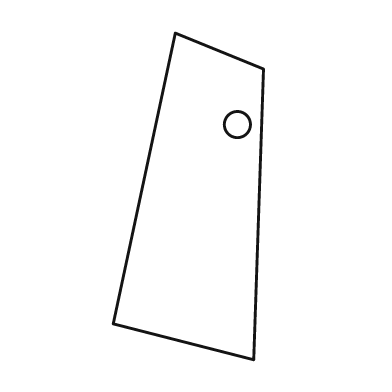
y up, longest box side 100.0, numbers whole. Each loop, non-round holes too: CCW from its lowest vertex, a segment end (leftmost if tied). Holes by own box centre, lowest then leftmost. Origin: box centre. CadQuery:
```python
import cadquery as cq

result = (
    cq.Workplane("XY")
    .moveTo(20.0, -50.0)
    .lineTo(23.0, 39.0)
    .lineTo(-4.0, 50.0)
    .lineTo(-23.0, -39.0)
    .close()
    .moveTo(15.0, 22.0)
    .circle(4.0)
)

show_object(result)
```